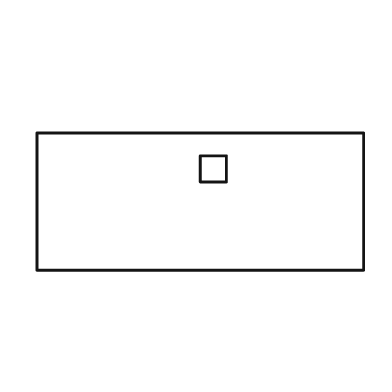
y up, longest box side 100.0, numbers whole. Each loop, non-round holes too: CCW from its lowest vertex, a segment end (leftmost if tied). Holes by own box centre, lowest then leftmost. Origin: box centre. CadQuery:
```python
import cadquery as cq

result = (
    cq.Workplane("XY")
    .moveTo(-50.0, -21.0)
    .lineTo(50.0, -21.0)
    .lineTo(50.0, 21.0)
    .lineTo(-50.0, 21.0)
    .close()
    .moveTo(0.0, 6.0)
    .lineTo(8.0, 6.0)
    .lineTo(8.0, 14.0)
    .lineTo(0.0, 14.0)
    .close()
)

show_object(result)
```